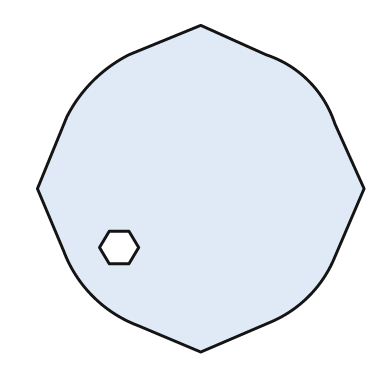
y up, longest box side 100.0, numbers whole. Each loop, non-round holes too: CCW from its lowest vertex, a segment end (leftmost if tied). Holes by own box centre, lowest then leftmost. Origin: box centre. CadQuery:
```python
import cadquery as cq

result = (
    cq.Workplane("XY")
    .moveTo(0.0, -50.0)
    .lineTo(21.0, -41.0)
    .threePointArc((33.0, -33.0), (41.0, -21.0))
    .lineTo(50.0, 0.0)
    .lineTo(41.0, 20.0)
    .threePointArc((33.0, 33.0), (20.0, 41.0))
    .lineTo(0.0, 50.0)
    .lineTo(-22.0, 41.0)
    .threePointArc((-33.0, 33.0), (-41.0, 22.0))
    .lineTo(-50.0, 0.0)
    .lineTo(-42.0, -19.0)
    .threePointArc((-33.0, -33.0), (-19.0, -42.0))
    .close()
    .moveTo(-28.0, -23.0)
    .lineTo(-22.0, -23.0)
    .lineTo(-19.0, -18.0)
    .lineTo(-22.0, -13.0)
    .lineTo(-28.0, -13.0)
    .lineTo(-31.0, -18.0)
    .close()
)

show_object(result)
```